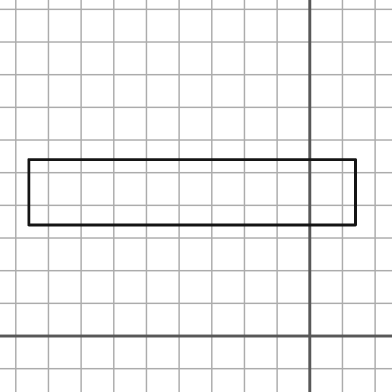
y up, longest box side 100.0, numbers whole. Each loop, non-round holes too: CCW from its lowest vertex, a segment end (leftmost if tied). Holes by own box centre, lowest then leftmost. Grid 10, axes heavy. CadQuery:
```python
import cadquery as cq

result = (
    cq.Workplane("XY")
    .moveTo(-86.0, 34.0)
    .lineTo(14.0, 34.0)
    .lineTo(14.0, 54.0)
    .lineTo(-86.0, 54.0)
    .close()
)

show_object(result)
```